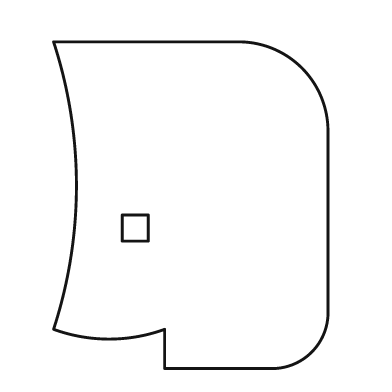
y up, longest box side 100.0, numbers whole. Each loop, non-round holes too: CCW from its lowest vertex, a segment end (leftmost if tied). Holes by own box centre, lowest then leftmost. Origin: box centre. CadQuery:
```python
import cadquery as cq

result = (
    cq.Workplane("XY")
    .moveTo(-8.0, -50.0)
    .lineTo(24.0, -50.0)
    .threePointArc((37.0, -45.0), (42.0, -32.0))
    .lineTo(42.0, 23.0)
    .threePointArc((34.0, 42.0), (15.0, 50.0))
    .lineTo(-42.0, 50.0)
    .threePointArc((-35.0, 6.0), (-42.0, -38.0))
    .threePointArc((-25.0, -41.0), (-8.0, -38.0))
    .close()
    .moveTo(-21.0, -11.0)
    .lineTo(-13.0, -11.0)
    .lineTo(-13.0, -3.0)
    .lineTo(-21.0, -3.0)
    .close()
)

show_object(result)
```